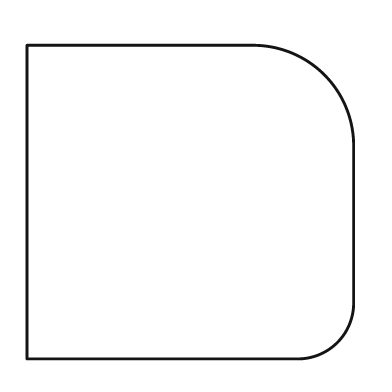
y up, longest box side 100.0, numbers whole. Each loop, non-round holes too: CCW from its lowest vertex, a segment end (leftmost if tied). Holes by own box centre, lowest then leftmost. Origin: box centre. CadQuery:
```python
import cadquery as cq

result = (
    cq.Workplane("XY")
    .moveTo(-50.0, -48.0)
    .lineTo(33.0, -48.0)
    .threePointArc((45.0, -43.0), (50.0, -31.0))
    .lineTo(50.0, 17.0)
    .threePointArc((41.0, 39.0), (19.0, 48.0))
    .lineTo(-50.0, 48.0)
    .close()
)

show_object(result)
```